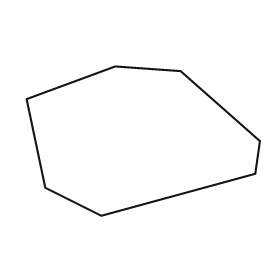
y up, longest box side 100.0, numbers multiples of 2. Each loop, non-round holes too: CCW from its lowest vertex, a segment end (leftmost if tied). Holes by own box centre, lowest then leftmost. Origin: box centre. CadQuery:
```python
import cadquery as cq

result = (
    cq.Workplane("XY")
    .moveTo(-18.0, -32.0)
    .lineTo(48.0, -14.0)
    .lineTo(50.0, 0.0)
    .lineTo(16.0, 30.0)
    .lineTo(-12.0, 32.0)
    .lineTo(-50.0, 18.0)
    .lineTo(-42.0, -20.0)
    .close()
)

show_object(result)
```